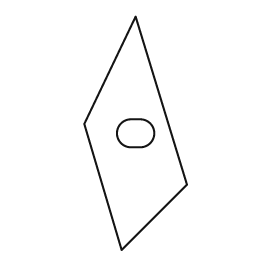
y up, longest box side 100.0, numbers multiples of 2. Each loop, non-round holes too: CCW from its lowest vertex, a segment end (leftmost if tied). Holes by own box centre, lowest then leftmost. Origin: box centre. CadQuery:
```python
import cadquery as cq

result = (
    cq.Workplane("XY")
    .moveTo(-6.0, -50.0)
    .lineTo(22.0, -22.0)
    .lineTo(0.0, 50.0)
    .lineTo(-22.0, 4.0)
    .close()
    .moveTo(-2.0, -6.0)
    .lineTo(2.0, -6.0)
    .threePointArc((8.0, 0.0), (2.0, 6.0))
    .lineTo(-2.0, 6.0)
    .threePointArc((-8.0, 0.0), (-2.0, -6.0))
    .close()
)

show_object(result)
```